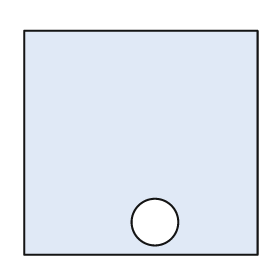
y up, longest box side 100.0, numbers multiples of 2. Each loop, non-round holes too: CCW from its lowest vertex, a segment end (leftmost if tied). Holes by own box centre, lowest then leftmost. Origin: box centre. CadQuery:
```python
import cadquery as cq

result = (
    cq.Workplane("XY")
    .moveTo(-50.0, -48.0)
    .lineTo(50.0, -48.0)
    .lineTo(50.0, 48.0)
    .lineTo(-50.0, 48.0)
    .close()
    .moveTo(6.0, -34.0)
    .circle(10.0)
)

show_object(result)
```